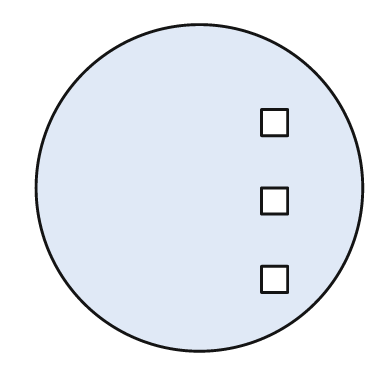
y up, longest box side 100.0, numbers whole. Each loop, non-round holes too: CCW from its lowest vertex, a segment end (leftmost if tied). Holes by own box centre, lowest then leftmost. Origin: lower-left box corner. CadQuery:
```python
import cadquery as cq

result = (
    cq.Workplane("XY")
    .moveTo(50.0, 50.0)
    .circle(50.0)
    .moveTo(69.0, 18.0)
    .lineTo(77.0, 18.0)
    .lineTo(77.0, 26.0)
    .lineTo(69.0, 26.0)
    .close()
    .moveTo(69.0, 42.0)
    .lineTo(77.0, 42.0)
    .lineTo(77.0, 50.0)
    .lineTo(69.0, 50.0)
    .close()
    .moveTo(69.0, 66.0)
    .lineTo(77.0, 66.0)
    .lineTo(77.0, 74.0)
    .lineTo(69.0, 74.0)
    .close()
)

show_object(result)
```